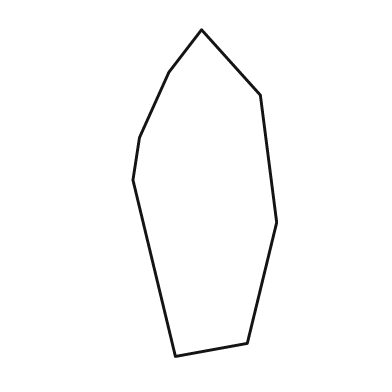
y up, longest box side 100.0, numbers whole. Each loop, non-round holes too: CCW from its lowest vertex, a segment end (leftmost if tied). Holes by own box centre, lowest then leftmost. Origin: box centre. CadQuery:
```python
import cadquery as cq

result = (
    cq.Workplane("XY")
    .moveTo(-9.0, -50.0)
    .lineTo(13.0, -46.0)
    .lineTo(22.0, -9.0)
    .lineTo(17.0, 30.0)
    .lineTo(-1.0, 50.0)
    .lineTo(-11.0, 37.0)
    .lineTo(-20.0, 17.0)
    .lineTo(-22.0, 4.0)
    .close()
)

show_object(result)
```